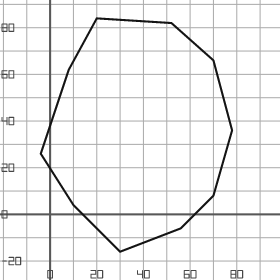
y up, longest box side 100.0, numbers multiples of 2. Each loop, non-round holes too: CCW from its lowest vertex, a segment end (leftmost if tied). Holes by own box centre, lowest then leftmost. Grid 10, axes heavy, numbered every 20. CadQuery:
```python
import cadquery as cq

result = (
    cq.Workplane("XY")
    .moveTo(30.0, -16.0)
    .lineTo(56.0, -6.0)
    .lineTo(70.0, 8.0)
    .lineTo(78.0, 36.0)
    .lineTo(70.0, 66.0)
    .lineTo(52.0, 82.0)
    .lineTo(20.0, 84.0)
    .lineTo(8.0, 62.0)
    .lineTo(-4.0, 26.0)
    .lineTo(10.0, 4.0)
    .close()
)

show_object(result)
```